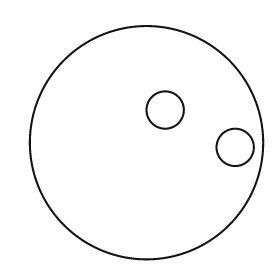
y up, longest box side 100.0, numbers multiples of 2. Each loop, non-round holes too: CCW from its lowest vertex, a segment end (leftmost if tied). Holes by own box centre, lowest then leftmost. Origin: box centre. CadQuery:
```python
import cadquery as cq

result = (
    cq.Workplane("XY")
    .moveTo(0.0, 0.0)
    .circle(50.0)
    .moveTo(38.0, -2.0)
    .circle(8.0)
    .moveTo(8.0, 14.0)
    .circle(8.0)
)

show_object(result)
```